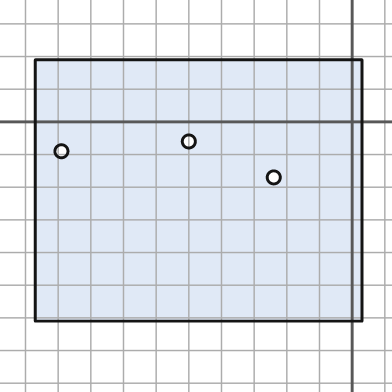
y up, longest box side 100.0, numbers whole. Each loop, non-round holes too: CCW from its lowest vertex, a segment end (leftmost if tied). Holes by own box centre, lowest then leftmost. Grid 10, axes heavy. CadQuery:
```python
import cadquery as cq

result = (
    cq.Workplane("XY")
    .moveTo(-97.0, -61.0)
    .lineTo(3.0, -61.0)
    .lineTo(3.0, 19.0)
    .lineTo(-97.0, 19.0)
    .close()
    .moveTo(-24.0, -17.0)
    .circle(2.0)
    .moveTo(-89.0, -9.0)
    .circle(2.0)
    .moveTo(-50.0, -6.0)
    .circle(2.0)
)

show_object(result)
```